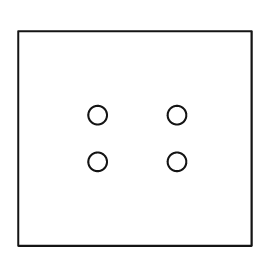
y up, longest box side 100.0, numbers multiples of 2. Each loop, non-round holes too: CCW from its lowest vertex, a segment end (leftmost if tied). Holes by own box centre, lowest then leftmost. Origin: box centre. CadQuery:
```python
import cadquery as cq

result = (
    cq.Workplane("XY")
    .moveTo(-50.0, -46.0)
    .lineTo(50.0, -46.0)
    .lineTo(50.0, 46.0)
    .lineTo(-50.0, 46.0)
    .close()
    .moveTo(-16.0, -10.0)
    .circle(4.0)
    .moveTo(18.0, -10.0)
    .circle(4.0)
    .moveTo(-16.0, 10.0)
    .circle(4.0)
    .moveTo(18.0, 10.0)
    .circle(4.0)
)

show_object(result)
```